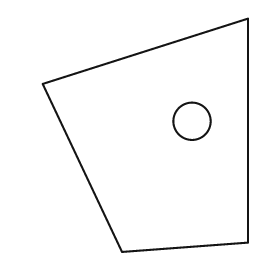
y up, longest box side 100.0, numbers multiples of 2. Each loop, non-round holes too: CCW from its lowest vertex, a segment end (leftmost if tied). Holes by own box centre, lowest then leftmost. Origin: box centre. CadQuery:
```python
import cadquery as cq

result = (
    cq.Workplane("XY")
    .moveTo(-10.0, -50.0)
    .lineTo(44.0, -46.0)
    .lineTo(44.0, 50.0)
    .lineTo(-44.0, 22.0)
    .close()
    .moveTo(20.0, 6.0)
    .circle(8.0)
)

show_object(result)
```